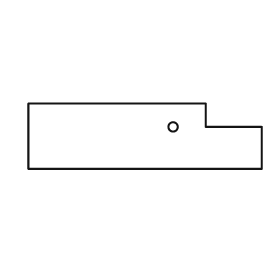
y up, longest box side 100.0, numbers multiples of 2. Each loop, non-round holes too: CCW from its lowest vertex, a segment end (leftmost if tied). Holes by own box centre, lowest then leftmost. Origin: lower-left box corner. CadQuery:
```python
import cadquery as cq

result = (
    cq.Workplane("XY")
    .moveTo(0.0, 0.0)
    .lineTo(100.0, 0.0)
    .lineTo(100.0, 18.0)
    .lineTo(76.0, 18.0)
    .lineTo(76.0, 28.0)
    .lineTo(0.0, 28.0)
    .close()
    .moveTo(62.0, 18.0)
    .circle(2.0)
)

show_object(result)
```